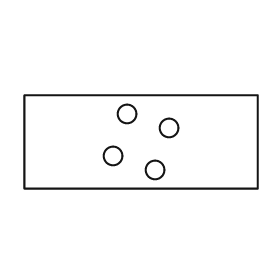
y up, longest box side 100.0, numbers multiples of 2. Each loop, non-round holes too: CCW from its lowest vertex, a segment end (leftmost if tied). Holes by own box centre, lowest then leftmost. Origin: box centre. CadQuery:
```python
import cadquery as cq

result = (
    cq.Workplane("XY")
    .moveTo(-50.0, -20.0)
    .lineTo(50.0, -20.0)
    .lineTo(50.0, 20.0)
    .lineTo(-50.0, 20.0)
    .close()
    .moveTo(6.0, -12.0)
    .circle(4.0)
    .moveTo(-12.0, -6.0)
    .circle(4.0)
    .moveTo(12.0, 6.0)
    .circle(4.0)
    .moveTo(-6.0, 12.0)
    .circle(4.0)
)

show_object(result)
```